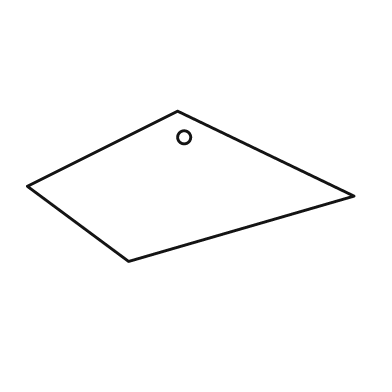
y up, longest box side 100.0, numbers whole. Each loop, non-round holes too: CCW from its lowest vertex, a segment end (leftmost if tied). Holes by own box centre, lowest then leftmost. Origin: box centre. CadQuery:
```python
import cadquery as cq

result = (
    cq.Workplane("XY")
    .moveTo(-19.0, -23.0)
    .lineTo(50.0, -3.0)
    .lineTo(-4.0, 23.0)
    .lineTo(-50.0, 0.0)
    .close()
    .moveTo(-2.0, 15.0)
    .circle(2.0)
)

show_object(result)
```